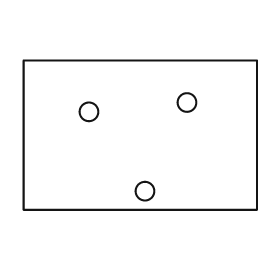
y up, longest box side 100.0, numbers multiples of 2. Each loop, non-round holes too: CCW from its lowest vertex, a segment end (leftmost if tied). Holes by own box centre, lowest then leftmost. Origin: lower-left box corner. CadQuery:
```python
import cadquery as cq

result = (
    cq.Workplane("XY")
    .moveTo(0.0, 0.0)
    .lineTo(100.0, 0.0)
    .lineTo(100.0, 64.0)
    .lineTo(0.0, 64.0)
    .close()
    .moveTo(52.0, 8.0)
    .circle(4.0)
    .moveTo(28.0, 42.0)
    .circle(4.0)
    .moveTo(70.0, 46.0)
    .circle(4.0)
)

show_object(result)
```